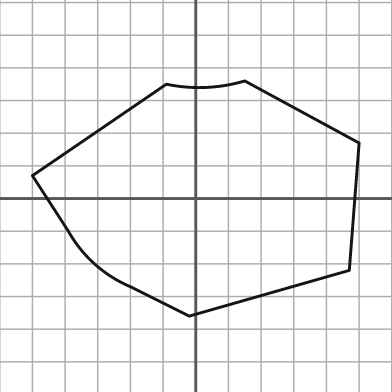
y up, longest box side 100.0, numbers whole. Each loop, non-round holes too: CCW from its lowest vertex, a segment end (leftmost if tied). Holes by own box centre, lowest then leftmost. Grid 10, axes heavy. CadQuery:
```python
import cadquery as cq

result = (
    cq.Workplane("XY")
    .moveTo(-2.0, -36.0)
    .lineTo(47.0, -22.0)
    .lineTo(50.0, 17.0)
    .lineTo(15.0, 36.0)
    .threePointArc((3.0, 34.0), (-9.0, 35.0))
    .lineTo(-50.0, 7.0)
    .lineTo(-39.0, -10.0)
    .threePointArc((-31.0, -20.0), (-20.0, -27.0))
    .close()
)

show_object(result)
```